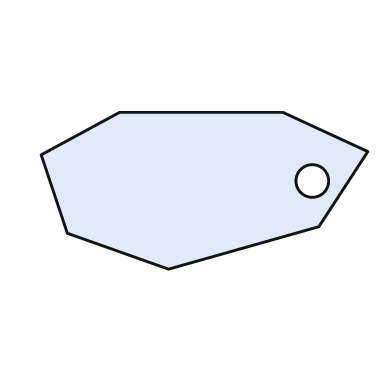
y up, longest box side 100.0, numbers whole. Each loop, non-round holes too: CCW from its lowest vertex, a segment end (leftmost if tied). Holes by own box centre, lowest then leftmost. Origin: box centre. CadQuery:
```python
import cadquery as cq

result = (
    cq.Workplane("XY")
    .moveTo(-11.0, -24.0)
    .lineTo(35.0, -11.0)
    .lineTo(50.0, 12.0)
    .lineTo(24.0, 24.0)
    .lineTo(-26.0, 24.0)
    .lineTo(-50.0, 11.0)
    .lineTo(-42.0, -13.0)
    .close()
    .moveTo(33.0, 3.0)
    .circle(5.0)
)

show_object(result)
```